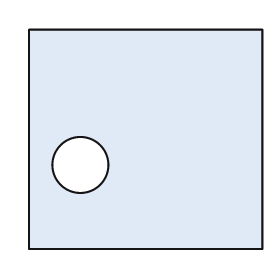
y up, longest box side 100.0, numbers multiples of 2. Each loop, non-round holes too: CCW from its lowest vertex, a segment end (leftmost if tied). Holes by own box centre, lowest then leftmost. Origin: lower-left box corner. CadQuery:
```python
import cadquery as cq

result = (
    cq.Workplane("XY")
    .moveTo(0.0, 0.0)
    .lineTo(100.0, 0.0)
    .lineTo(100.0, 94.0)
    .lineTo(0.0, 94.0)
    .close()
    .moveTo(22.0, 36.0)
    .circle(12.0)
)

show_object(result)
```